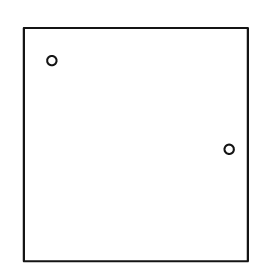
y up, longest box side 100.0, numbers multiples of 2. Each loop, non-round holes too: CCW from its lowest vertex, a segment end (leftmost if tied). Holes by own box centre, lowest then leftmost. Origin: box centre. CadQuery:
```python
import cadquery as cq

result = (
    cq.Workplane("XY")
    .moveTo(-48.0, -50.0)
    .lineTo(48.0, -50.0)
    .lineTo(48.0, 50.0)
    .lineTo(-48.0, 50.0)
    .close()
    .moveTo(40.0, -2.0)
    .circle(2.0)
    .moveTo(-36.0, 36.0)
    .circle(2.0)
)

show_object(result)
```